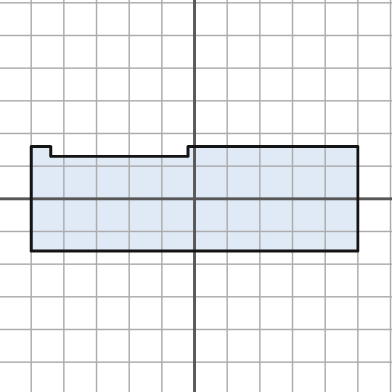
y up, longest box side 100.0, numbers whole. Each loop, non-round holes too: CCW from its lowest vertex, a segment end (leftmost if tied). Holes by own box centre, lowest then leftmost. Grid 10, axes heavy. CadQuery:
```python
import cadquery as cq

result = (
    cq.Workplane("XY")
    .moveTo(-50.0, -16.0)
    .lineTo(50.0, -16.0)
    .lineTo(50.0, 16.0)
    .lineTo(-2.0, 16.0)
    .lineTo(-2.0, 13.0)
    .lineTo(-44.0, 13.0)
    .lineTo(-44.0, 16.0)
    .lineTo(-50.0, 16.0)
    .close()
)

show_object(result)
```